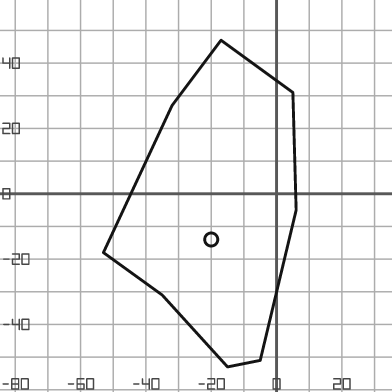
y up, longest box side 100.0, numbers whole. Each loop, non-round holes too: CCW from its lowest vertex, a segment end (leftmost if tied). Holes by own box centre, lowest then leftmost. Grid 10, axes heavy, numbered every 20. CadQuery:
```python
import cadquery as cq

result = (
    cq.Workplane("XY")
    .moveTo(-15.0, -53.0)
    .lineTo(-5.0, -51.0)
    .lineTo(6.0, -5.0)
    .lineTo(5.0, 31.0)
    .lineTo(-17.0, 47.0)
    .lineTo(-32.0, 27.0)
    .lineTo(-53.0, -18.0)
    .lineTo(-35.0, -31.0)
    .close()
    .moveTo(-20.0, -14.0)
    .circle(2.0)
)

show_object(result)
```